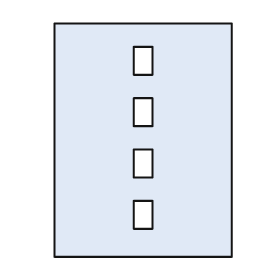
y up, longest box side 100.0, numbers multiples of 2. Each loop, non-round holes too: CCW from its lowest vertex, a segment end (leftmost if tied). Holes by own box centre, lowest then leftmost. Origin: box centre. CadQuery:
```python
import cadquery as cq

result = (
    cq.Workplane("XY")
    .moveTo(-38.0, -50.0)
    .lineTo(38.0, -50.0)
    .lineTo(38.0, 50.0)
    .lineTo(-38.0, 50.0)
    .close()
    .moveTo(-4.0, -38.0)
    .lineTo(4.0, -38.0)
    .lineTo(4.0, -26.0)
    .lineTo(-4.0, -26.0)
    .close()
    .moveTo(-4.0, -16.0)
    .lineTo(4.0, -16.0)
    .lineTo(4.0, -4.0)
    .lineTo(-4.0, -4.0)
    .close()
    .moveTo(-4.0, 6.0)
    .lineTo(4.0, 6.0)
    .lineTo(4.0, 18.0)
    .lineTo(-4.0, 18.0)
    .close()
    .moveTo(-4.0, 28.0)
    .lineTo(4.0, 28.0)
    .lineTo(4.0, 40.0)
    .lineTo(-4.0, 40.0)
    .close()
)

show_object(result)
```